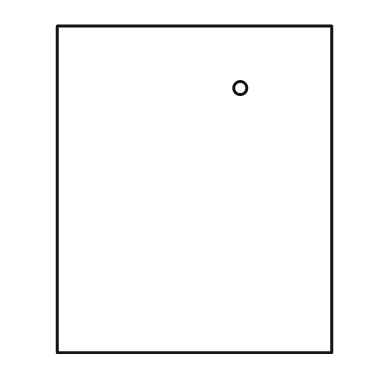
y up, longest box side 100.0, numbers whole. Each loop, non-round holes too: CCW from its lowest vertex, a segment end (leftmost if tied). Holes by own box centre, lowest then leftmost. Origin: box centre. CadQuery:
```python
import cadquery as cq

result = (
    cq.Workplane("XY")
    .moveTo(-42.0, -50.0)
    .lineTo(42.0, -50.0)
    .lineTo(42.0, 50.0)
    .lineTo(-42.0, 50.0)
    .close()
    .moveTo(14.0, 31.0)
    .circle(2.0)
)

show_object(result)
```